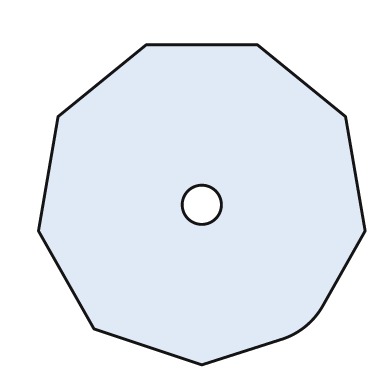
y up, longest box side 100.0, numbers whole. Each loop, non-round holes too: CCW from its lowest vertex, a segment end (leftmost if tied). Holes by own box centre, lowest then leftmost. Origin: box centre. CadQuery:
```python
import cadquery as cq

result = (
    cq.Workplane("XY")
    .moveTo(0.0, -49.0)
    .lineTo(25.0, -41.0)
    .threePointArc((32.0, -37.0), (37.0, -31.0))
    .lineTo(50.0, -8.0)
    .lineTo(44.0, 27.0)
    .lineTo(17.0, 49.0)
    .lineTo(-17.0, 49.0)
    .lineTo(-44.0, 27.0)
    .lineTo(-50.0, -8.0)
    .lineTo(-33.0, -38.0)
    .close()
    .moveTo(0.0, 0.0)
    .circle(6.0)
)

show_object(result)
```